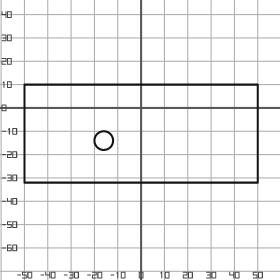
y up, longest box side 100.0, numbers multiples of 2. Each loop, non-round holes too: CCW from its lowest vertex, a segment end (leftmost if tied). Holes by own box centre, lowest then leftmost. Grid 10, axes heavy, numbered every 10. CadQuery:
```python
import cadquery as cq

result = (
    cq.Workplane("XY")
    .moveTo(-50.0, -32.0)
    .lineTo(50.0, -32.0)
    .lineTo(50.0, 10.0)
    .lineTo(-50.0, 10.0)
    .close()
    .moveTo(-16.0, -14.0)
    .circle(4.0)
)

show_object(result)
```